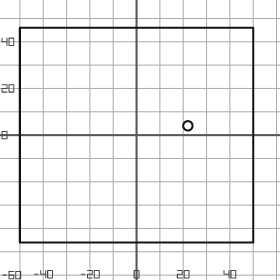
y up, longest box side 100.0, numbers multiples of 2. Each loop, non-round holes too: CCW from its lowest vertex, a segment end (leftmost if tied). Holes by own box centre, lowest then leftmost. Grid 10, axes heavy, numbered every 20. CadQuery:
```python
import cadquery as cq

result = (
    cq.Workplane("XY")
    .moveTo(-50.0, -46.0)
    .lineTo(50.0, -46.0)
    .lineTo(50.0, 46.0)
    .lineTo(-50.0, 46.0)
    .close()
    .moveTo(22.0, 4.0)
    .circle(2.0)
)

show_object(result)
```